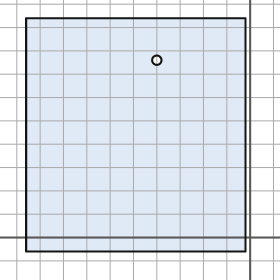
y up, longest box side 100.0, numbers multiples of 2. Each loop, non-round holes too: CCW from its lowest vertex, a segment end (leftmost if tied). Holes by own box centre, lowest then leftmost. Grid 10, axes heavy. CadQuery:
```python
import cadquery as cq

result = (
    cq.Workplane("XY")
    .moveTo(-96.0, -6.0)
    .lineTo(-2.0, -6.0)
    .lineTo(-2.0, 94.0)
    .lineTo(-96.0, 94.0)
    .close()
    .moveTo(-40.0, 76.0)
    .circle(2.0)
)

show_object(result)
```